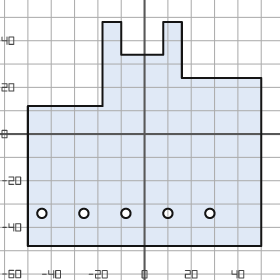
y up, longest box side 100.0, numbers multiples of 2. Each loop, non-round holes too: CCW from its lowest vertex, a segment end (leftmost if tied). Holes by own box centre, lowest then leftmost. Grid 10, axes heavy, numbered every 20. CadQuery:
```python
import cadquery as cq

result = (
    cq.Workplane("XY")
    .moveTo(-50.0, -48.0)
    .lineTo(50.0, -48.0)
    .lineTo(50.0, 24.0)
    .lineTo(16.0, 24.0)
    .lineTo(16.0, 48.0)
    .lineTo(8.0, 48.0)
    .lineTo(8.0, 34.0)
    .lineTo(-10.0, 34.0)
    .lineTo(-10.0, 48.0)
    .lineTo(-18.0, 48.0)
    .lineTo(-18.0, 12.0)
    .lineTo(-50.0, 12.0)
    .close()
    .moveTo(-44.0, -34.0)
    .circle(2.0)
    .moveTo(-26.0, -34.0)
    .circle(2.0)
    .moveTo(-8.0, -34.0)
    .circle(2.0)
    .moveTo(10.0, -34.0)
    .circle(2.0)
    .moveTo(28.0, -34.0)
    .circle(2.0)
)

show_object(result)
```